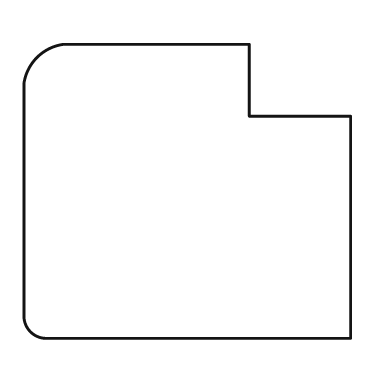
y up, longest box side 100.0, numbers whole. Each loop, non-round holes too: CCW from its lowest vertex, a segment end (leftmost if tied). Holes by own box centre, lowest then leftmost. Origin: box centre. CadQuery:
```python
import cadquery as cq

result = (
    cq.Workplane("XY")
    .moveTo(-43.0, -45.0)
    .lineTo(50.0, -45.0)
    .lineTo(50.0, 23.0)
    .lineTo(19.0, 23.0)
    .lineTo(19.0, 45.0)
    .lineTo(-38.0, 45.0)
    .threePointArc((-46.0, 41.0), (-50.0, 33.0))
    .lineTo(-50.0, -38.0)
    .threePointArc((-48.0, -43.0), (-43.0, -45.0))
    .close()
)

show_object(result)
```